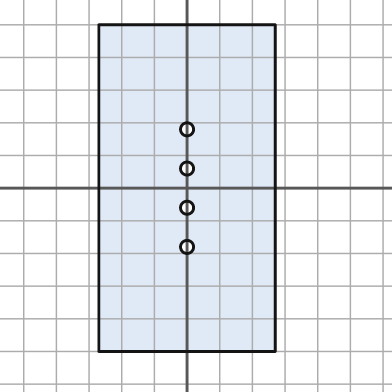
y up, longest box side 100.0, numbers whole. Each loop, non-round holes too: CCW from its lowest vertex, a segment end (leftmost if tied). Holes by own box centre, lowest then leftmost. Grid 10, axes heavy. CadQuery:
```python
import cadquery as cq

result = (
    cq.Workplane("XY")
    .moveTo(-27.0, -50.0)
    .lineTo(27.0, -50.0)
    .lineTo(27.0, 50.0)
    .lineTo(-27.0, 50.0)
    .close()
    .moveTo(0.0, -18.0)
    .circle(2.0)
    .moveTo(0.0, -6.0)
    .circle(2.0)
    .moveTo(0.0, 6.0)
    .circle(2.0)
    .moveTo(0.0, 18.0)
    .circle(2.0)
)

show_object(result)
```